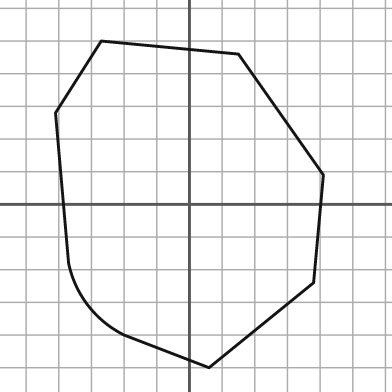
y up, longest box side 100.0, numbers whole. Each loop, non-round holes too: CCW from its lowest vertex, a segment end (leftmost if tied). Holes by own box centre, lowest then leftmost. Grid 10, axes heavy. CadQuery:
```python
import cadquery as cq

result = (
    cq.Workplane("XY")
    .moveTo(6.0, -50.0)
    .lineTo(38.0, -24.0)
    .lineTo(41.0, 9.0)
    .lineTo(15.0, 46.0)
    .lineTo(-27.0, 50.0)
    .lineTo(-41.0, 28.0)
    .lineTo(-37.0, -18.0)
    .threePointArc((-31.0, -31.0), (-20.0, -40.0))
    .close()
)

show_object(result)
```